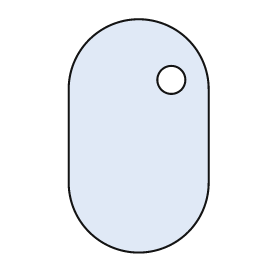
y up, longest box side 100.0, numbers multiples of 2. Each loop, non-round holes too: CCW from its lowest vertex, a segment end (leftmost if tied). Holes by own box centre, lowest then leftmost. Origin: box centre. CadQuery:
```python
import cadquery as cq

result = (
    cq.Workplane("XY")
    .moveTo(-30.0, -20.0)
    .threePointArc((0.0, -50.0), (30.0, -20.0))
    .lineTo(30.0, 20.0)
    .threePointArc((0.0, 50.0), (-30.0, 20.0))
    .close()
    .moveTo(14.0, 24.0)
    .circle(6.0)
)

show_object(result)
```